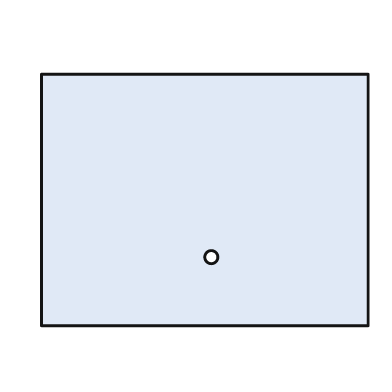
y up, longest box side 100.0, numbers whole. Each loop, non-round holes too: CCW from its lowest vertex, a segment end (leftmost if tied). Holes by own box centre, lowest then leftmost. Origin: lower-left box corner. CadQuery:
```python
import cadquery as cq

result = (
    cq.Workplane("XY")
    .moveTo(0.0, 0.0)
    .lineTo(100.0, 0.0)
    .lineTo(100.0, 77.0)
    .lineTo(0.0, 77.0)
    .close()
    .moveTo(52.0, 21.0)
    .circle(2.0)
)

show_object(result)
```